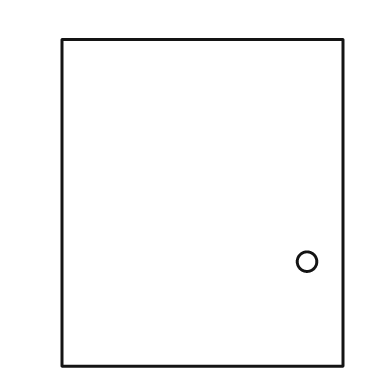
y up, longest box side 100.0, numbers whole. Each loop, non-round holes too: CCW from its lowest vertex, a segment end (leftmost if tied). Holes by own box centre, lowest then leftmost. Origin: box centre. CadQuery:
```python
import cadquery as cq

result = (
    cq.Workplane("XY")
    .moveTo(-43.0, -50.0)
    .lineTo(43.0, -50.0)
    .lineTo(43.0, 50.0)
    .lineTo(-43.0, 50.0)
    .close()
    .moveTo(32.0, -18.0)
    .circle(3.0)
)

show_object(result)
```